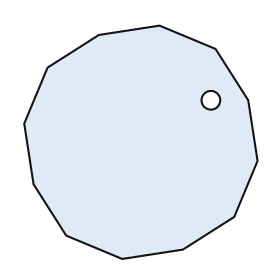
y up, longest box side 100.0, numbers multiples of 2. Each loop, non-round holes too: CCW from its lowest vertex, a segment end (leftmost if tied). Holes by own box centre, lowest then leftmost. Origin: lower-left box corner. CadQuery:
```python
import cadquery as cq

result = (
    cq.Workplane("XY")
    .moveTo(42.0, 0.0)
    .lineTo(68.0, 4.0)
    .lineTo(90.0, 18.0)
    .lineTo(100.0, 42.0)
    .lineTo(96.0, 68.0)
    .lineTo(82.0, 90.0)
    .lineTo(58.0, 100.0)
    .lineTo(32.0, 96.0)
    .lineTo(10.0, 82.0)
    .lineTo(0.0, 58.0)
    .lineTo(4.0, 32.0)
    .lineTo(18.0, 10.0)
    .close()
    .moveTo(80.0, 68.0)
    .circle(4.0)
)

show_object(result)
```